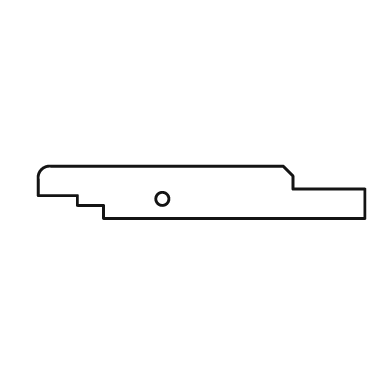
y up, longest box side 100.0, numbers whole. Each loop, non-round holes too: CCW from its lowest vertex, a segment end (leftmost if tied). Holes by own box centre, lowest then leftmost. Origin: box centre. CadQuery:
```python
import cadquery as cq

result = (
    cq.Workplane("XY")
    .moveTo(-30.0, -8.0)
    .lineTo(50.0, -8.0)
    .lineTo(50.0, 1.0)
    .lineTo(28.0, 1.0)
    .lineTo(28.0, 5.0)
    .lineTo(25.0, 8.0)
    .lineTo(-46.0, 8.0)
    .threePointArc((-49.0, 7.0), (-50.0, 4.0))
    .lineTo(-50.0, -1.0)
    .lineTo(-38.0, -1.0)
    .lineTo(-38.0, -4.0)
    .lineTo(-30.0, -4.0)
    .close()
    .moveTo(-12.0, -2.0)
    .circle(2.0)
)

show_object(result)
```